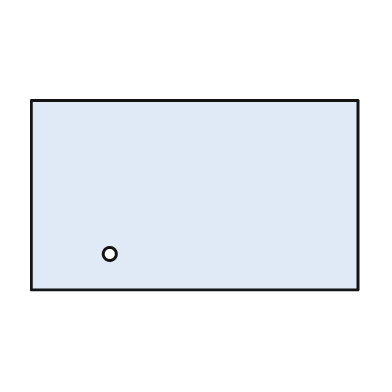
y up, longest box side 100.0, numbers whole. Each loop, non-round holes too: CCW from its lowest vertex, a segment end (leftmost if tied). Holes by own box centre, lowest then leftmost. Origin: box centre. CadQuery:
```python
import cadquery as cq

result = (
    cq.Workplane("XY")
    .moveTo(-50.0, -29.0)
    .lineTo(50.0, -29.0)
    .lineTo(50.0, 29.0)
    .lineTo(-50.0, 29.0)
    .close()
    .moveTo(-26.0, -18.0)
    .circle(2.0)
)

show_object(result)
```